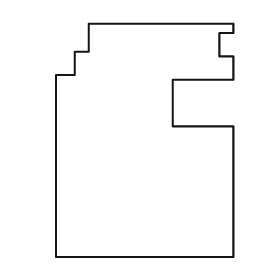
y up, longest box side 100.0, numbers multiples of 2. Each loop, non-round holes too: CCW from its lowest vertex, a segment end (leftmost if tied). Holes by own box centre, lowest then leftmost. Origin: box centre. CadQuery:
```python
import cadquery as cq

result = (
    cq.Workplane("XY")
    .moveTo(-38.0, -50.0)
    .lineTo(38.0, -50.0)
    .lineTo(38.0, 6.0)
    .lineTo(12.0, 6.0)
    .lineTo(12.0, 26.0)
    .lineTo(38.0, 26.0)
    .lineTo(38.0, 36.0)
    .lineTo(32.0, 36.0)
    .lineTo(32.0, 46.0)
    .lineTo(38.0, 46.0)
    .lineTo(38.0, 50.0)
    .lineTo(-24.0, 50.0)
    .lineTo(-24.0, 38.0)
    .lineTo(-30.0, 38.0)
    .lineTo(-30.0, 28.0)
    .lineTo(-38.0, 28.0)
    .close()
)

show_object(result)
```